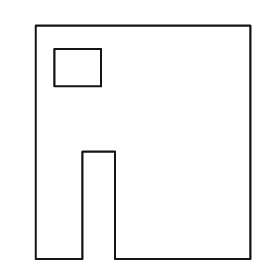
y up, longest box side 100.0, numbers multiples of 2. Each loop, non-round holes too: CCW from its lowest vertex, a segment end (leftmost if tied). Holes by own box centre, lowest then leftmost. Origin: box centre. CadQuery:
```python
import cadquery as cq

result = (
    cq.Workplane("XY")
    .moveTo(-46.0, -50.0)
    .lineTo(-26.0, -50.0)
    .lineTo(-26.0, -4.0)
    .lineTo(-12.0, -4.0)
    .lineTo(-12.0, -50.0)
    .lineTo(46.0, -50.0)
    .lineTo(46.0, 50.0)
    .lineTo(-46.0, 50.0)
    .close()
    .moveTo(-38.0, 24.0)
    .lineTo(-18.0, 24.0)
    .lineTo(-18.0, 40.0)
    .lineTo(-38.0, 40.0)
    .close()
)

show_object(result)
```